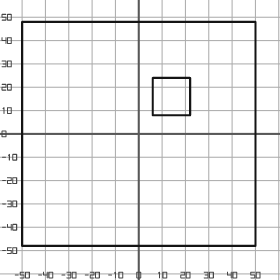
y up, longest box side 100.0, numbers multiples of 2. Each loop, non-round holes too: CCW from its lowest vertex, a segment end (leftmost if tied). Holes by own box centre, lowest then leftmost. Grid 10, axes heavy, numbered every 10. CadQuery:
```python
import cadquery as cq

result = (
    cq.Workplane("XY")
    .moveTo(-50.0, -48.0)
    .lineTo(50.0, -48.0)
    .lineTo(50.0, 48.0)
    .lineTo(-50.0, 48.0)
    .close()
    .moveTo(6.0, 8.0)
    .lineTo(22.0, 8.0)
    .lineTo(22.0, 24.0)
    .lineTo(6.0, 24.0)
    .close()
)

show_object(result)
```